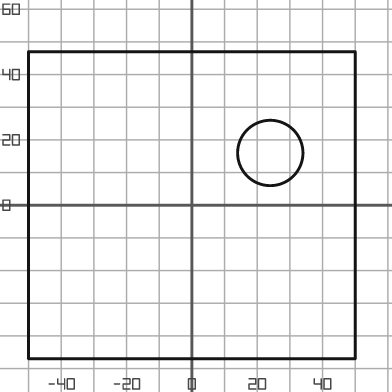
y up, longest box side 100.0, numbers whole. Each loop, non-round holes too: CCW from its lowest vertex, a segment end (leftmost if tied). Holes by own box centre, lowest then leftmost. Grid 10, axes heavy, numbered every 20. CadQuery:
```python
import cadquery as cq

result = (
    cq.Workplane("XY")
    .moveTo(-50.0, -47.0)
    .lineTo(50.0, -47.0)
    .lineTo(50.0, 47.0)
    .lineTo(-50.0, 47.0)
    .close()
    .moveTo(24.0, 16.0)
    .circle(10.0)
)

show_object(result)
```